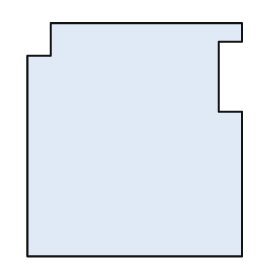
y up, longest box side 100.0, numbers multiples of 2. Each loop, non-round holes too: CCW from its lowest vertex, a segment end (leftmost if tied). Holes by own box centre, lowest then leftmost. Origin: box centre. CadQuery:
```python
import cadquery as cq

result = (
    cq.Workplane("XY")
    .moveTo(-46.0, -50.0)
    .lineTo(46.0, -50.0)
    .lineTo(46.0, 12.0)
    .lineTo(36.0, 12.0)
    .lineTo(36.0, 42.0)
    .lineTo(46.0, 42.0)
    .lineTo(46.0, 50.0)
    .lineTo(-36.0, 50.0)
    .lineTo(-36.0, 36.0)
    .lineTo(-46.0, 36.0)
    .close()
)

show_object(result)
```